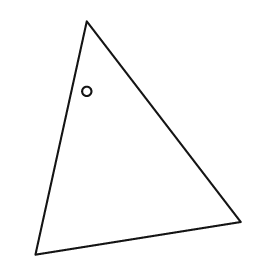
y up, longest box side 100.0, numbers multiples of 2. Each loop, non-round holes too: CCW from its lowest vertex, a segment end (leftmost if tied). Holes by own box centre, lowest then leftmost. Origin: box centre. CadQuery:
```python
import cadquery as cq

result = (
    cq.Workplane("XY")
    .moveTo(-44.0, -50.0)
    .lineTo(44.0, -36.0)
    .lineTo(-22.0, 50.0)
    .close()
    .moveTo(-22.0, 20.0)
    .circle(2.0)
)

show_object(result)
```